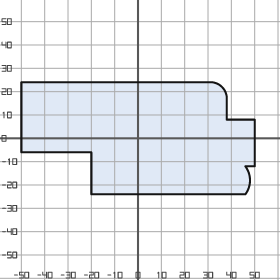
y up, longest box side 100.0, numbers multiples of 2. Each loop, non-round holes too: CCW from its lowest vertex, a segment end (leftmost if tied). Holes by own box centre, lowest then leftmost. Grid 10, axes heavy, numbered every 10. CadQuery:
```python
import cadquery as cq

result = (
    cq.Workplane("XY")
    .moveTo(-20.0, -24.0)
    .lineTo(46.0, -24.0)
    .threePointArc((48.0, -18.0), (46.0, -12.0))
    .lineTo(50.0, -12.0)
    .lineTo(50.0, 8.0)
    .lineTo(38.0, 8.0)
    .lineTo(38.0, 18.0)
    .threePointArc((36.0, 22.0), (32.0, 24.0))
    .lineTo(-50.0, 24.0)
    .lineTo(-50.0, -6.0)
    .lineTo(-20.0, -6.0)
    .close()
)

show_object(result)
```